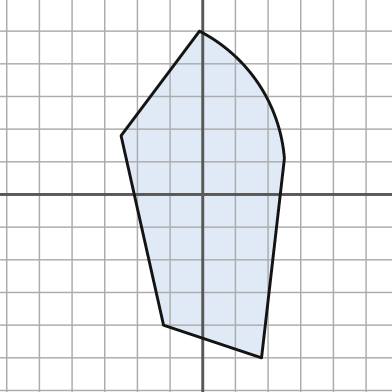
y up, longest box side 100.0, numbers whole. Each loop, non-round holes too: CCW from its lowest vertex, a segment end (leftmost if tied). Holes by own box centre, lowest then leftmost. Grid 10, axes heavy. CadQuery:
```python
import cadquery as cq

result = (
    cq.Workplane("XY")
    .moveTo(18.0, -50.0)
    .lineTo(25.0, 11.0)
    .threePointArc((17.0, 34.0), (-1.0, 50.0))
    .lineTo(-25.0, 18.0)
    .lineTo(-12.0, -40.0)
    .close()
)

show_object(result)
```